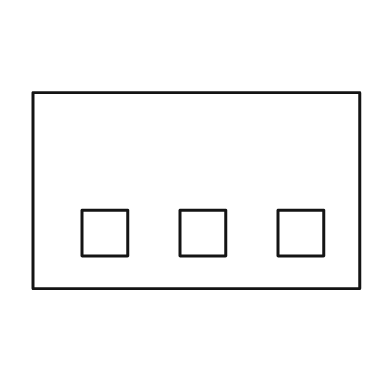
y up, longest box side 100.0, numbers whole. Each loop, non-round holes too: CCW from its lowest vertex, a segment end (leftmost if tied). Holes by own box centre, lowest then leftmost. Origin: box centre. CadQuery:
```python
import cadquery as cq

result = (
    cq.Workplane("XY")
    .moveTo(-50.0, -30.0)
    .lineTo(50.0, -30.0)
    .lineTo(50.0, 30.0)
    .lineTo(-50.0, 30.0)
    .close()
    .moveTo(-35.0, -20.0)
    .lineTo(-21.0, -20.0)
    .lineTo(-21.0, -6.0)
    .lineTo(-35.0, -6.0)
    .close()
    .moveTo(-5.0, -20.0)
    .lineTo(9.0, -20.0)
    .lineTo(9.0, -6.0)
    .lineTo(-5.0, -6.0)
    .close()
    .moveTo(25.0, -20.0)
    .lineTo(39.0, -20.0)
    .lineTo(39.0, -6.0)
    .lineTo(25.0, -6.0)
    .close()
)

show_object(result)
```